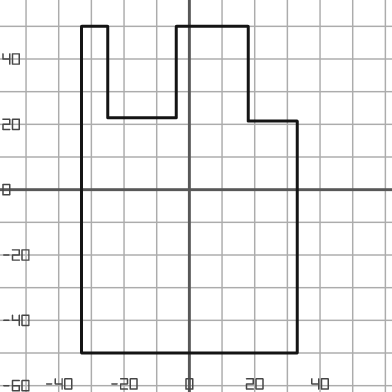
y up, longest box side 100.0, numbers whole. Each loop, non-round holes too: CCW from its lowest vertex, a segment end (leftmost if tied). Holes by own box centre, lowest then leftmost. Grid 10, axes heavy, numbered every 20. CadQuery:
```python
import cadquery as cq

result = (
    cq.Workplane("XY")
    .moveTo(-33.0, -50.0)
    .lineTo(33.0, -50.0)
    .lineTo(33.0, 21.0)
    .lineTo(18.0, 21.0)
    .lineTo(18.0, 50.0)
    .lineTo(-4.0, 50.0)
    .lineTo(-4.0, 22.0)
    .lineTo(-25.0, 22.0)
    .lineTo(-25.0, 50.0)
    .lineTo(-33.0, 50.0)
    .close()
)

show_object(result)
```